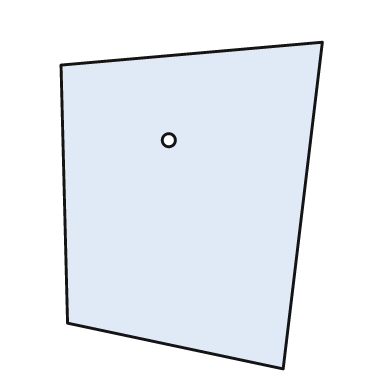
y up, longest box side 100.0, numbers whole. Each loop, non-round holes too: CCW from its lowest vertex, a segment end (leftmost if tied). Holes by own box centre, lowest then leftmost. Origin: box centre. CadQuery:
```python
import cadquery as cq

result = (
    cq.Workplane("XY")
    .moveTo(28.0, -50.0)
    .lineTo(40.0, 50.0)
    .lineTo(-40.0, 43.0)
    .lineTo(-38.0, -36.0)
    .close()
    .moveTo(-7.0, 20.0)
    .circle(2.0)
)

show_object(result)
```